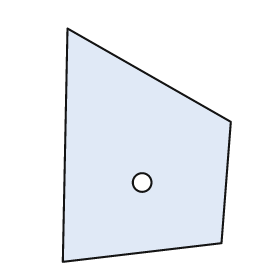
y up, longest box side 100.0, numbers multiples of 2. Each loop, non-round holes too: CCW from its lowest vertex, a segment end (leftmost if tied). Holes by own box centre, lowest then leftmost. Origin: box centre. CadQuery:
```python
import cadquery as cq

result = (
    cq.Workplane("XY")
    .moveTo(-36.0, -50.0)
    .lineTo(32.0, -42.0)
    .lineTo(36.0, 10.0)
    .lineTo(-34.0, 50.0)
    .close()
    .moveTo(-2.0, -16.0)
    .circle(4.0)
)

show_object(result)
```